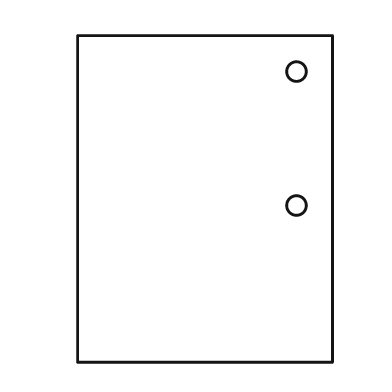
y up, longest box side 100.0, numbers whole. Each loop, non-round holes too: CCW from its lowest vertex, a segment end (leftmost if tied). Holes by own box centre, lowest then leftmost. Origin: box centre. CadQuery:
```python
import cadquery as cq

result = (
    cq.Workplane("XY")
    .moveTo(-39.0, -50.0)
    .lineTo(39.0, -50.0)
    .lineTo(39.0, 50.0)
    .lineTo(-39.0, 50.0)
    .close()
    .moveTo(28.0, -2.0)
    .circle(3.0)
    .moveTo(28.0, 39.0)
    .circle(3.0)
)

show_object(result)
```